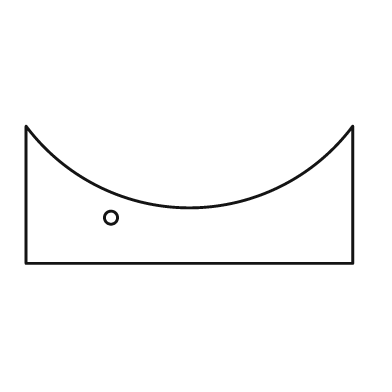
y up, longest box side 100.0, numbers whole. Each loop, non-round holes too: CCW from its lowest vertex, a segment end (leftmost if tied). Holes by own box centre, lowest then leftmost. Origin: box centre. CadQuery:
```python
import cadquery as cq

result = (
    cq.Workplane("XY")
    .moveTo(-50.0, -21.0)
    .lineTo(50.0, -21.0)
    .lineTo(50.0, 21.0)
    .threePointArc((0.0, -4.0), (-50.0, 21.0))
    .close()
    .moveTo(-24.0, -7.0)
    .circle(2.0)
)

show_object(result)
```